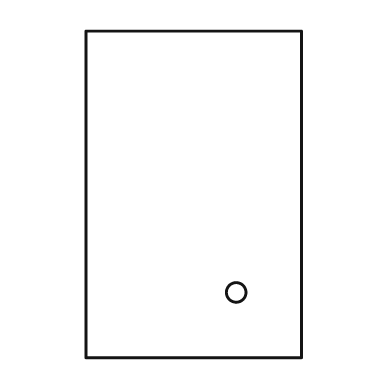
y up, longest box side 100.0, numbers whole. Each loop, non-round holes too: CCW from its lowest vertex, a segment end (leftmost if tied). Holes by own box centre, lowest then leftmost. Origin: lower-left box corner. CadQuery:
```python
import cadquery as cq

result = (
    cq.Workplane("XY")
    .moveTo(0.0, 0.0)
    .lineTo(66.0, 0.0)
    .lineTo(66.0, 100.0)
    .lineTo(0.0, 100.0)
    .close()
    .moveTo(46.0, 20.0)
    .circle(3.0)
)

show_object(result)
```